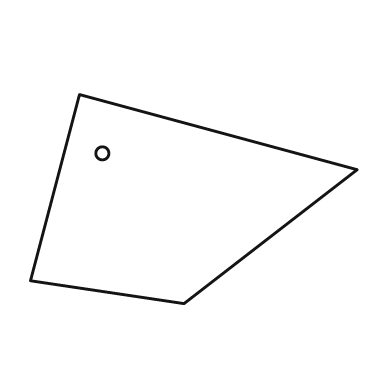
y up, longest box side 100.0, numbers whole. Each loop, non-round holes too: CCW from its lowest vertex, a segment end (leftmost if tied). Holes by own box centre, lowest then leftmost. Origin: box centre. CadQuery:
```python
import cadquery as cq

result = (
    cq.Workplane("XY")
    .moveTo(-3.0, -32.0)
    .lineTo(50.0, 9.0)
    .lineTo(-35.0, 32.0)
    .lineTo(-50.0, -25.0)
    .close()
    .moveTo(-28.0, 14.0)
    .circle(2.0)
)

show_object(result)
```